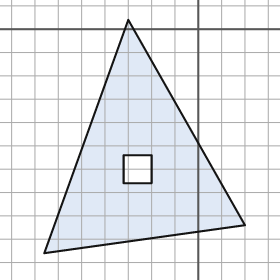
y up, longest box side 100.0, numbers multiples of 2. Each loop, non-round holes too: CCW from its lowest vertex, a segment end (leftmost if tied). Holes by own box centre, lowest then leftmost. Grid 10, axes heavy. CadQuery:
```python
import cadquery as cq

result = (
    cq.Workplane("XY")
    .moveTo(-66.0, -96.0)
    .lineTo(20.0, -84.0)
    .lineTo(-30.0, 4.0)
    .close()
    .moveTo(-32.0, -66.0)
    .lineTo(-20.0, -66.0)
    .lineTo(-20.0, -54.0)
    .lineTo(-32.0, -54.0)
    .close()
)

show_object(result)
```